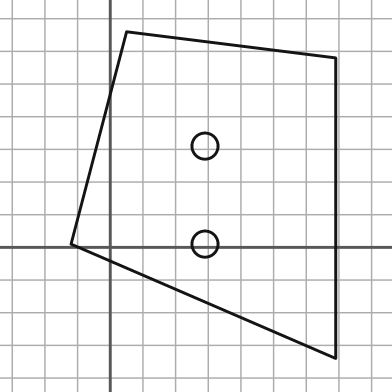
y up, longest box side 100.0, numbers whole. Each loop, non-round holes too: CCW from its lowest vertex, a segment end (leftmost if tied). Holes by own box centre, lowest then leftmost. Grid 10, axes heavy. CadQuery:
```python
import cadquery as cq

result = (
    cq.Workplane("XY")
    .moveTo(69.0, -34.0)
    .lineTo(69.0, 58.0)
    .lineTo(5.0, 66.0)
    .lineTo(-12.0, 1.0)
    .close()
    .moveTo(29.0, 1.0)
    .circle(4.0)
    .moveTo(29.0, 31.0)
    .circle(4.0)
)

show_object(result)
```